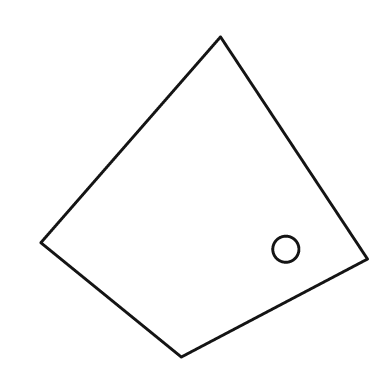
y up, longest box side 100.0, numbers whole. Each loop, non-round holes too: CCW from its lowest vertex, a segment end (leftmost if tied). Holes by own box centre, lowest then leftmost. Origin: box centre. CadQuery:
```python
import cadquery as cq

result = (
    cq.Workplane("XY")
    .moveTo(-7.0, -49.0)
    .lineTo(50.0, -19.0)
    .lineTo(5.0, 49.0)
    .lineTo(-50.0, -14.0)
    .close()
    .moveTo(25.0, -16.0)
    .circle(4.0)
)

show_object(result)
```